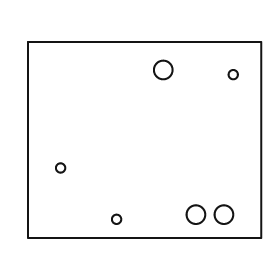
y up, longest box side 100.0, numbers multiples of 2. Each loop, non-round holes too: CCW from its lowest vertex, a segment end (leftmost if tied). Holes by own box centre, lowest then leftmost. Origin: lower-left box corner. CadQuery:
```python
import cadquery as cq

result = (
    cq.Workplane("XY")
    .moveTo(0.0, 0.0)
    .lineTo(100.0, 0.0)
    .lineTo(100.0, 84.0)
    .lineTo(0.0, 84.0)
    .close()
    .moveTo(38.0, 8.0)
    .circle(2.0)
    .moveTo(72.0, 10.0)
    .circle(4.0)
    .moveTo(84.0, 10.0)
    .circle(4.0)
    .moveTo(14.0, 30.0)
    .circle(2.0)
    .moveTo(88.0, 70.0)
    .circle(2.0)
    .moveTo(58.0, 72.0)
    .circle(4.0)
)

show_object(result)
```